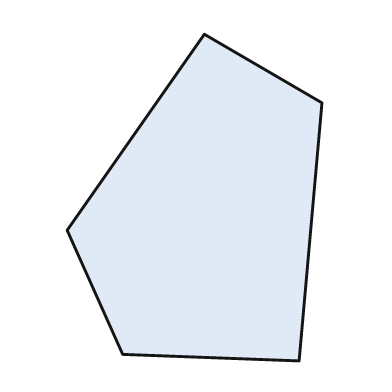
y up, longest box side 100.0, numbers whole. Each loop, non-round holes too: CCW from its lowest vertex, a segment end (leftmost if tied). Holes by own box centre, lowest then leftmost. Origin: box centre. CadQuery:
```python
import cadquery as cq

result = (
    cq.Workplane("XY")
    .moveTo(32.0, -50.0)
    .lineTo(39.0, 29.0)
    .lineTo(3.0, 50.0)
    .lineTo(-39.0, -10.0)
    .lineTo(-22.0, -48.0)
    .close()
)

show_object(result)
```